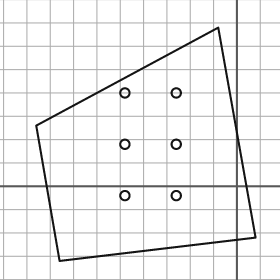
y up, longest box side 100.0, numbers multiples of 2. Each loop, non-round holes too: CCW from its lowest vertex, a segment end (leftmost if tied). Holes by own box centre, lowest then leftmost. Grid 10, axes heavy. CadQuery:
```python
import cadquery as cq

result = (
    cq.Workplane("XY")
    .moveTo(-76.0, -32.0)
    .lineTo(8.0, -22.0)
    .lineTo(-8.0, 68.0)
    .lineTo(-86.0, 26.0)
    .close()
    .moveTo(-48.0, -4.0)
    .circle(2.0)
    .moveTo(-26.0, -4.0)
    .circle(2.0)
    .moveTo(-48.0, 18.0)
    .circle(2.0)
    .moveTo(-26.0, 18.0)
    .circle(2.0)
    .moveTo(-48.0, 40.0)
    .circle(2.0)
    .moveTo(-26.0, 40.0)
    .circle(2.0)
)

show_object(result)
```